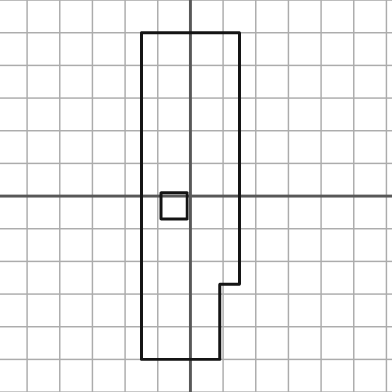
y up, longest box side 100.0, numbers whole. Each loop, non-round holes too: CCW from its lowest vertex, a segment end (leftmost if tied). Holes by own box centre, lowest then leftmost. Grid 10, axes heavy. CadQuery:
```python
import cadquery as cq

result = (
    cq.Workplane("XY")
    .moveTo(-15.0, -50.0)
    .lineTo(9.0, -50.0)
    .lineTo(9.0, -27.0)
    .lineTo(15.0, -27.0)
    .lineTo(15.0, 50.0)
    .lineTo(-15.0, 50.0)
    .close()
    .moveTo(-9.0, -7.0)
    .lineTo(-1.0, -7.0)
    .lineTo(-1.0, 1.0)
    .lineTo(-9.0, 1.0)
    .close()
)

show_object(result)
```